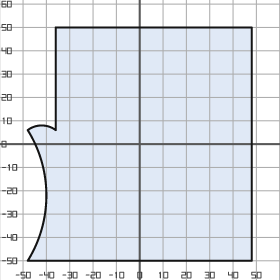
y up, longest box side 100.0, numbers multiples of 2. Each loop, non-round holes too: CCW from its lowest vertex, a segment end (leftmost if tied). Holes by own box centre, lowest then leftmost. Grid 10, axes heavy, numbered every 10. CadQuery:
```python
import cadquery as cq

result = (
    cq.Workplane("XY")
    .moveTo(-48.0, -50.0)
    .lineTo(48.0, -50.0)
    .lineTo(48.0, 50.0)
    .lineTo(-36.0, 50.0)
    .lineTo(-36.0, 6.0)
    .threePointArc((-42.0, 8.0), (-48.0, 6.0))
    .threePointArc((-40.0, -22.0), (-48.0, -50.0))
    .close()
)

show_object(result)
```